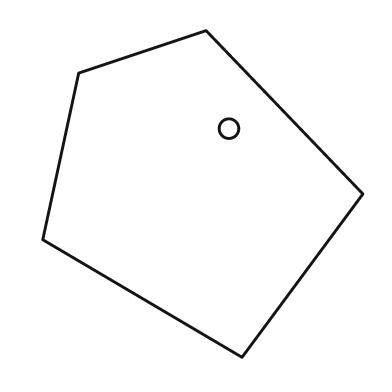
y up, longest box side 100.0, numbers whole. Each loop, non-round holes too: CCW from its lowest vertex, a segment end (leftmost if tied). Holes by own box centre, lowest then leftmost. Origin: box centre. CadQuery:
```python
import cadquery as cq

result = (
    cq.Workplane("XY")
    .moveTo(12.0, -50.0)
    .lineTo(49.0, 0.0)
    .lineTo(1.0, 50.0)
    .lineTo(-38.0, 37.0)
    .lineTo(-49.0, -14.0)
    .close()
    .moveTo(8.0, 20.0)
    .circle(3.0)
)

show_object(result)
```